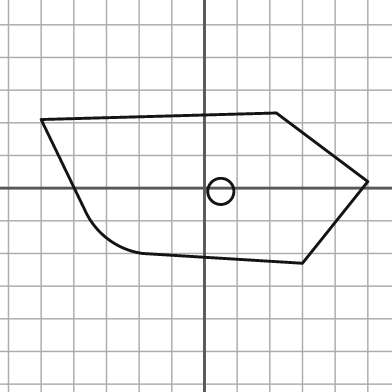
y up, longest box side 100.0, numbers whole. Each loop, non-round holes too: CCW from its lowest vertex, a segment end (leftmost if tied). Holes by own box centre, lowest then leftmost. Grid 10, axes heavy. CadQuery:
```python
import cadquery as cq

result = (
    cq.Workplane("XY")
    .moveTo(30.0, -23.0)
    .lineTo(50.0, 2.0)
    .lineTo(22.0, 23.0)
    .lineTo(-50.0, 21.0)
    .lineTo(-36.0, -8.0)
    .threePointArc((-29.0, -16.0), (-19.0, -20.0))
    .close()
    .moveTo(5.0, -1.0)
    .circle(4.0)
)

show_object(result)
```